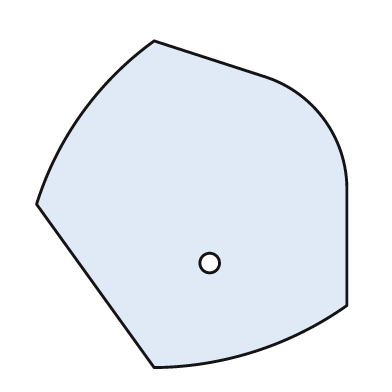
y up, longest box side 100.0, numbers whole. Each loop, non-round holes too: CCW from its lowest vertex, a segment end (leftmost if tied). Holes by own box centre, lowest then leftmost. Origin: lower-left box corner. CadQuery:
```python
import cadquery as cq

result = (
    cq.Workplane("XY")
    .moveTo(36.0, 0.0)
    .threePointArc((67.0, 5.0), (95.0, 19.0))
    .lineTo(95.0, 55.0)
    .threePointArc((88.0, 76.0), (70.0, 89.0))
    .lineTo(36.0, 100.0)
    .threePointArc((14.0, 78.0), (0.0, 50.0))
    .close()
    .moveTo(53.0, 32.0)
    .circle(3.0)
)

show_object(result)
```